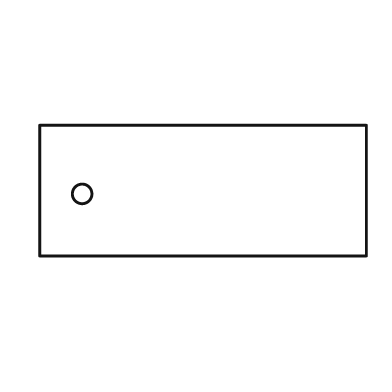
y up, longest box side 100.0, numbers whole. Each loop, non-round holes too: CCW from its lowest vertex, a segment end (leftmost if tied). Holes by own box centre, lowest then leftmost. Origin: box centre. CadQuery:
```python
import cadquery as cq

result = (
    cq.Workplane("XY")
    .moveTo(-50.0, -20.0)
    .lineTo(50.0, -20.0)
    .lineTo(50.0, 20.0)
    .lineTo(-50.0, 20.0)
    .close()
    .moveTo(-37.0, -1.0)
    .circle(3.0)
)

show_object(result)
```